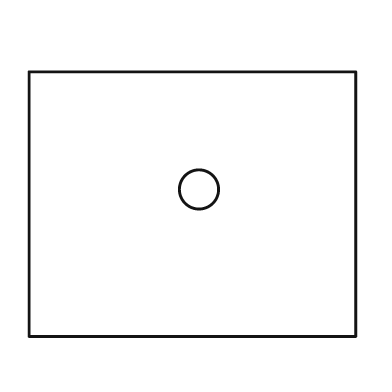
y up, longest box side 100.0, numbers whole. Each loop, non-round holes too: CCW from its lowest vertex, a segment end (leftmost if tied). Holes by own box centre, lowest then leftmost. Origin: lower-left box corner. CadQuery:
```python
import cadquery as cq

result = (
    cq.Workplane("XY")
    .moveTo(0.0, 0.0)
    .lineTo(100.0, 0.0)
    .lineTo(100.0, 81.0)
    .lineTo(0.0, 81.0)
    .close()
    .moveTo(52.0, 45.0)
    .circle(6.0)
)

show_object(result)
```